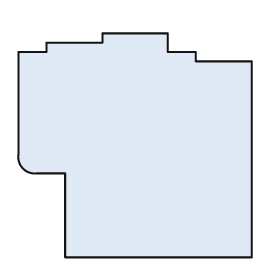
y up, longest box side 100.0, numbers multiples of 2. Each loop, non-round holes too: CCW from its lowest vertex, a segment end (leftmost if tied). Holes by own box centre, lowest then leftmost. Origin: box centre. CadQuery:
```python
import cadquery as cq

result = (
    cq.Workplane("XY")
    .moveTo(-30.0, -48.0)
    .lineTo(50.0, -48.0)
    .lineTo(50.0, 36.0)
    .lineTo(26.0, 36.0)
    .lineTo(26.0, 40.0)
    .lineTo(14.0, 40.0)
    .lineTo(14.0, 48.0)
    .lineTo(-14.0, 48.0)
    .lineTo(-14.0, 44.0)
    .lineTo(-38.0, 44.0)
    .lineTo(-38.0, 40.0)
    .lineTo(-50.0, 40.0)
    .lineTo(-50.0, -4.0)
    .threePointArc((-48.0, -10.0), (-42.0, -12.0))
    .lineTo(-30.0, -12.0)
    .close()
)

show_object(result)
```